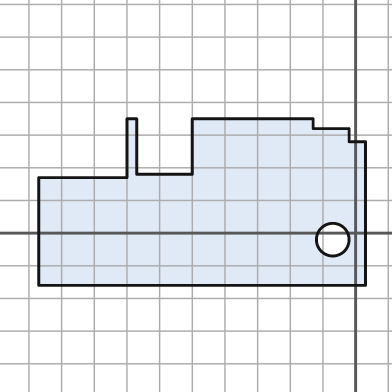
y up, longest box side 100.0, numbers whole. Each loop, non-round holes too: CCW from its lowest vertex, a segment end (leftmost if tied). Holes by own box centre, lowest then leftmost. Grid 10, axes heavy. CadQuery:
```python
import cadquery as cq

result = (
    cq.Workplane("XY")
    .moveTo(-97.0, -16.0)
    .lineTo(3.0, -16.0)
    .lineTo(3.0, 28.0)
    .lineTo(-2.0, 28.0)
    .lineTo(-2.0, 32.0)
    .lineTo(-13.0, 32.0)
    .lineTo(-13.0, 35.0)
    .lineTo(-50.0, 35.0)
    .lineTo(-50.0, 18.0)
    .lineTo(-67.0, 18.0)
    .lineTo(-67.0, 35.0)
    .lineTo(-70.0, 35.0)
    .lineTo(-70.0, 17.0)
    .lineTo(-97.0, 17.0)
    .close()
    .moveTo(-7.0, -2.0)
    .circle(5.0)
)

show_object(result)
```